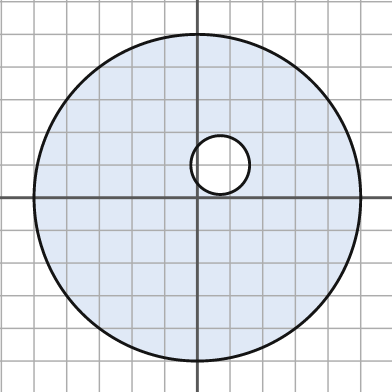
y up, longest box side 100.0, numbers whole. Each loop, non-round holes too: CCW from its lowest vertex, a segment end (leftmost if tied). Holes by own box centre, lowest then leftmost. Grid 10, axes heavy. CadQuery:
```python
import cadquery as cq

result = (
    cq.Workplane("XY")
    .moveTo(0.0, 0.0)
    .circle(50.0)
    .moveTo(7.0, 10.0)
    .circle(9.0)
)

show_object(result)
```